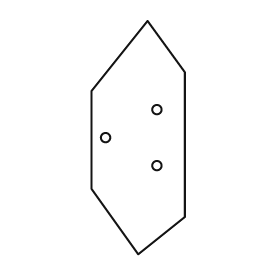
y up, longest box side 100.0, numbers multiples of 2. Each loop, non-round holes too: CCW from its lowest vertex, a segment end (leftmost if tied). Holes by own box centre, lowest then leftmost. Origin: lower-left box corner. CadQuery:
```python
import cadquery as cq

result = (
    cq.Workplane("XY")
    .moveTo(20.0, 0.0)
    .lineTo(40.0, 16.0)
    .lineTo(40.0, 78.0)
    .lineTo(24.0, 100.0)
    .lineTo(0.0, 70.0)
    .lineTo(0.0, 28.0)
    .close()
    .moveTo(28.0, 38.0)
    .circle(2.0)
    .moveTo(6.0, 50.0)
    .circle(2.0)
    .moveTo(28.0, 62.0)
    .circle(2.0)
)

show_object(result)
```